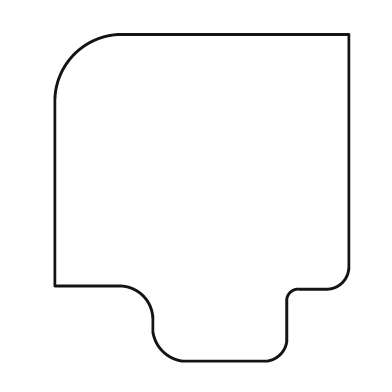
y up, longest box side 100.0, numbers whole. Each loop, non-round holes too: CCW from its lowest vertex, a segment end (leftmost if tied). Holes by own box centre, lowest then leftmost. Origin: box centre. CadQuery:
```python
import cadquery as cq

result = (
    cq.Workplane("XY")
    .moveTo(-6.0, -50.0)
    .lineTo(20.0, -50.0)
    .threePointArc((24.0, -48.0), (26.0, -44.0))
    .lineTo(26.0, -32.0)
    .threePointArc((27.0, -29.0), (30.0, -28.0))
    .lineTo(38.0, -28.0)
    .threePointArc((43.0, -26.0), (45.0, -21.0))
    .lineTo(45.0, 50.0)
    .lineTo(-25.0, 50.0)
    .threePointArc((-39.0, 44.0), (-45.0, 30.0))
    .lineTo(-45.0, -27.0)
    .lineTo(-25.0, -27.0)
    .threePointArc((-18.0, -30.0), (-15.0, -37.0))
    .lineTo(-15.0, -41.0)
    .threePointArc((-12.0, -47.0), (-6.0, -50.0))
    .close()
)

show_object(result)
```